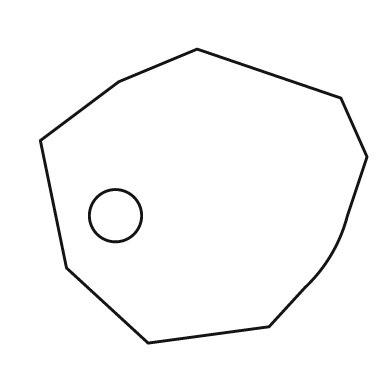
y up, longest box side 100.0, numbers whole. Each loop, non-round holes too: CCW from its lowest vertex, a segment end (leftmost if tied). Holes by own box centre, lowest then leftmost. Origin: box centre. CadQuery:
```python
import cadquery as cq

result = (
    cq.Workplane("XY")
    .moveTo(-17.0, -45.0)
    .lineTo(20.0, -40.0)
    .lineTo(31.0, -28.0)
    .threePointArc((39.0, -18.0), (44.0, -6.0))
    .lineTo(50.0, 12.0)
    .lineTo(42.0, 30.0)
    .lineTo(-2.0, 45.0)
    .lineTo(-26.0, 35.0)
    .lineTo(-50.0, 17.0)
    .lineTo(-42.0, -22.0)
    .close()
    .moveTo(-27.0, -6.0)
    .circle(8.0)
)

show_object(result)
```